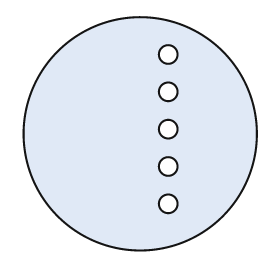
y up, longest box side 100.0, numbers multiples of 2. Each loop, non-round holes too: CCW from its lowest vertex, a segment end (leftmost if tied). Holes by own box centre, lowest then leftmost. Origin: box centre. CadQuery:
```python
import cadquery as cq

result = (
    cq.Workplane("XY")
    .moveTo(0.0, 0.0)
    .circle(50.0)
    .moveTo(12.0, -30.0)
    .circle(4.0)
    .moveTo(12.0, -14.0)
    .circle(4.0)
    .moveTo(12.0, 2.0)
    .circle(4.0)
    .moveTo(12.0, 18.0)
    .circle(4.0)
    .moveTo(12.0, 34.0)
    .circle(4.0)
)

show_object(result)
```